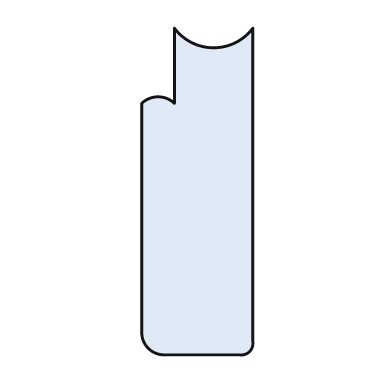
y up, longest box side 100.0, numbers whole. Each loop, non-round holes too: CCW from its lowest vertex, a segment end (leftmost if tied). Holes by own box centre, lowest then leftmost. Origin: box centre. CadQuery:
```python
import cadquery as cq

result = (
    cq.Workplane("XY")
    .moveTo(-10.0, -50.0)
    .lineTo(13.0, -50.0)
    .threePointArc((16.0, -49.0), (17.0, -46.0))
    .lineTo(17.0, 50.0)
    .threePointArc((5.0, 44.0), (-7.0, 50.0))
    .lineTo(-7.0, 27.0)
    .threePointArc((-12.0, 29.0), (-17.0, 27.0))
    .lineTo(-17.0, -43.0)
    .threePointArc((-15.0, -48.0), (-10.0, -50.0))
    .close()
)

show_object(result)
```